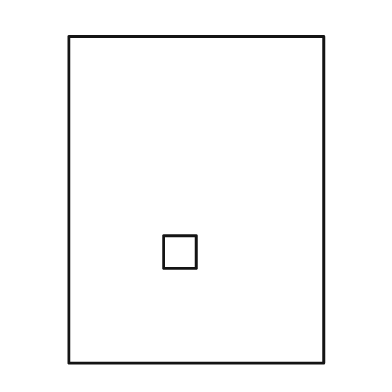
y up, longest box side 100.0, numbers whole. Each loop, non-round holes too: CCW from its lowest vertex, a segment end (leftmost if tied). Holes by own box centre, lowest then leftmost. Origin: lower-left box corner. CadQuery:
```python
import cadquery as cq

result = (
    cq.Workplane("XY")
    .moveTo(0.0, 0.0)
    .lineTo(78.0, 0.0)
    .lineTo(78.0, 100.0)
    .lineTo(0.0, 100.0)
    .close()
    .moveTo(29.0, 29.0)
    .lineTo(39.0, 29.0)
    .lineTo(39.0, 39.0)
    .lineTo(29.0, 39.0)
    .close()
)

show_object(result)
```